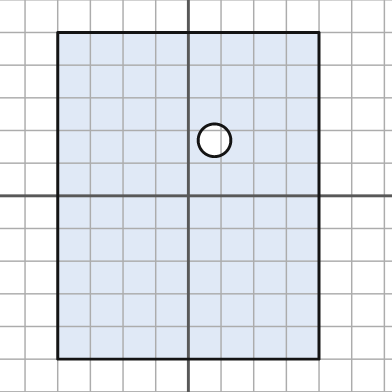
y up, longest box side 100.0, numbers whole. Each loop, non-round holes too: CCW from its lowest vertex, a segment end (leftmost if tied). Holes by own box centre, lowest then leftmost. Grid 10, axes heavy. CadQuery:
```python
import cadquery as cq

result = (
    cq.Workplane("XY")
    .moveTo(-40.0, -50.0)
    .lineTo(40.0, -50.0)
    .lineTo(40.0, 50.0)
    .lineTo(-40.0, 50.0)
    .close()
    .moveTo(8.0, 17.0)
    .circle(5.0)
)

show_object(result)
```